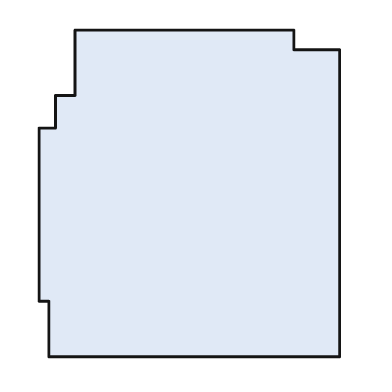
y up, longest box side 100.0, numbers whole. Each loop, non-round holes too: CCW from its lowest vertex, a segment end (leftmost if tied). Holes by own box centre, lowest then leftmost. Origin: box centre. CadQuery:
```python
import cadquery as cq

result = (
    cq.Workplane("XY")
    .moveTo(-43.0, -50.0)
    .lineTo(46.0, -50.0)
    .lineTo(46.0, 44.0)
    .lineTo(32.0, 44.0)
    .lineTo(32.0, 50.0)
    .lineTo(-35.0, 50.0)
    .lineTo(-35.0, 30.0)
    .lineTo(-41.0, 30.0)
    .lineTo(-41.0, 20.0)
    .lineTo(-46.0, 20.0)
    .lineTo(-46.0, -33.0)
    .lineTo(-43.0, -33.0)
    .close()
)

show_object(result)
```